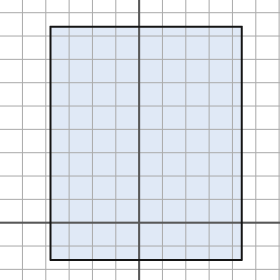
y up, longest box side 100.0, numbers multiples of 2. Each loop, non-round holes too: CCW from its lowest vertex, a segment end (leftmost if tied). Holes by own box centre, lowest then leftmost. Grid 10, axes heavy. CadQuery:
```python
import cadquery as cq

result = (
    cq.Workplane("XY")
    .moveTo(-38.0, -16.0)
    .lineTo(44.0, -16.0)
    .lineTo(44.0, 84.0)
    .lineTo(-38.0, 84.0)
    .close()
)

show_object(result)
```